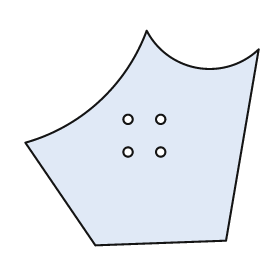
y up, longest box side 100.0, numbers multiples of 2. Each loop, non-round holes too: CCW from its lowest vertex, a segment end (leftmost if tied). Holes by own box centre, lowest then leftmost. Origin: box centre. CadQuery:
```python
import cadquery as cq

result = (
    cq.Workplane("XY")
    .moveTo(-20.0, -46.0)
    .lineTo(36.0, -44.0)
    .lineTo(50.0, 38.0)
    .threePointArc((24.0, 30.0), (2.0, 46.0))
    .threePointArc((-18.0, 16.0), (-50.0, -2.0))
    .close()
    .moveTo(-6.0, -6.0)
    .circle(2.0)
    .moveTo(8.0, -6.0)
    .circle(2.0)
    .moveTo(-6.0, 8.0)
    .circle(2.0)
    .moveTo(8.0, 8.0)
    .circle(2.0)
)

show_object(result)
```